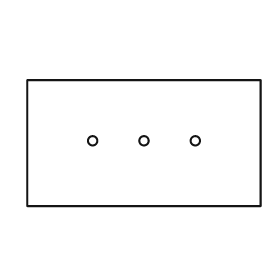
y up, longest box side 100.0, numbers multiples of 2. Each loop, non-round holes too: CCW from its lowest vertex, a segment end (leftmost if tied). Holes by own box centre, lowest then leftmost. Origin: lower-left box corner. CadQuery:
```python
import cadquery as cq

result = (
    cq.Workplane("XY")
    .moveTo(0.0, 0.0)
    .lineTo(100.0, 0.0)
    .lineTo(100.0, 54.0)
    .lineTo(0.0, 54.0)
    .close()
    .moveTo(28.0, 28.0)
    .circle(2.0)
    .moveTo(50.0, 28.0)
    .circle(2.0)
    .moveTo(72.0, 28.0)
    .circle(2.0)
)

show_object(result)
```